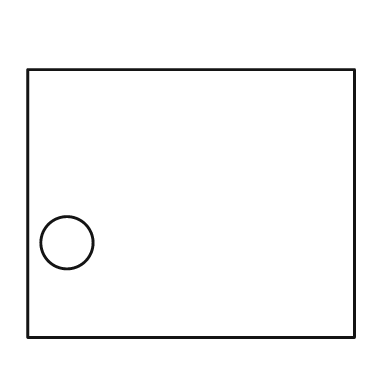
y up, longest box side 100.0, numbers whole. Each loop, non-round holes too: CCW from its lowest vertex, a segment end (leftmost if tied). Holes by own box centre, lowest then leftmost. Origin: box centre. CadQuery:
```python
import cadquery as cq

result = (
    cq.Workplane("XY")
    .moveTo(-50.0, -41.0)
    .lineTo(50.0, -41.0)
    .lineTo(50.0, 41.0)
    .lineTo(-50.0, 41.0)
    .close()
    .moveTo(-38.0, -12.0)
    .circle(8.0)
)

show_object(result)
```